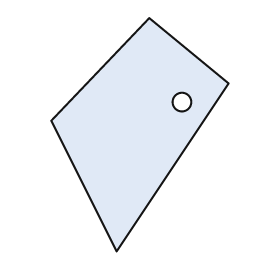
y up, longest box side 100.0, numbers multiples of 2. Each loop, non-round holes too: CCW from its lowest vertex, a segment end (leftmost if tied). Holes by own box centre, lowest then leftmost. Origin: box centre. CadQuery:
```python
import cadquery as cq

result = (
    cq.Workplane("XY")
    .moveTo(-10.0, -50.0)
    .lineTo(38.0, 22.0)
    .lineTo(4.0, 50.0)
    .lineTo(-38.0, 6.0)
    .close()
    .moveTo(18.0, 14.0)
    .circle(4.0)
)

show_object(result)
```